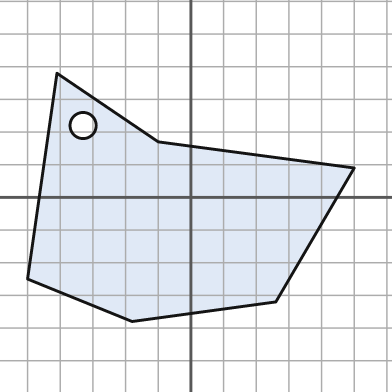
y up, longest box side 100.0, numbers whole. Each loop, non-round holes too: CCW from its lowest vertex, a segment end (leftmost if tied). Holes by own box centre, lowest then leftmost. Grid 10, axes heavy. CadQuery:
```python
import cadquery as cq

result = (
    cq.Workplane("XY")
    .moveTo(-18.0, -38.0)
    .lineTo(26.0, -32.0)
    .lineTo(50.0, 9.0)
    .lineTo(-10.0, 17.0)
    .lineTo(-41.0, 38.0)
    .lineTo(-50.0, -25.0)
    .close()
    .moveTo(-33.0, 22.0)
    .circle(4.0)
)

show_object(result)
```